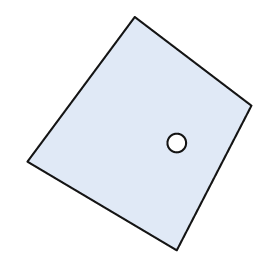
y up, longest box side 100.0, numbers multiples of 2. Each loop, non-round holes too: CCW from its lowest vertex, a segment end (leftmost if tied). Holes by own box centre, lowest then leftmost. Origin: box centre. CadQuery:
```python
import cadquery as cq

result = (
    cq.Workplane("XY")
    .moveTo(16.0, -50.0)
    .lineTo(48.0, 12.0)
    .lineTo(-2.0, 50.0)
    .lineTo(-48.0, -12.0)
    .close()
    .moveTo(16.0, -4.0)
    .circle(4.0)
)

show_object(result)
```